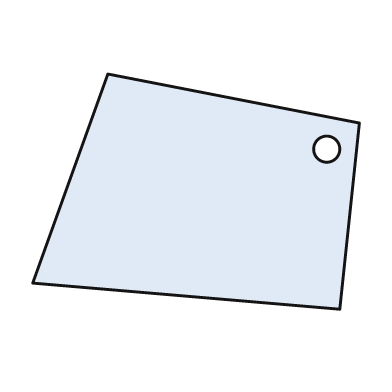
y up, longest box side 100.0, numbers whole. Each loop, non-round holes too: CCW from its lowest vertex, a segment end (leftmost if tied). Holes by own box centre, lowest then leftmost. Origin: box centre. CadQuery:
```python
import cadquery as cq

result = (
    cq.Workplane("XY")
    .moveTo(44.0, -36.0)
    .lineTo(50.0, 21.0)
    .lineTo(-27.0, 36.0)
    .lineTo(-50.0, -28.0)
    .close()
    .moveTo(40.0, 13.0)
    .circle(4.0)
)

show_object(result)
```